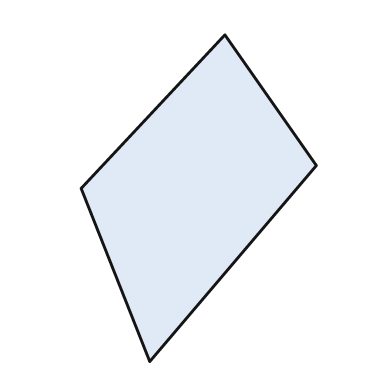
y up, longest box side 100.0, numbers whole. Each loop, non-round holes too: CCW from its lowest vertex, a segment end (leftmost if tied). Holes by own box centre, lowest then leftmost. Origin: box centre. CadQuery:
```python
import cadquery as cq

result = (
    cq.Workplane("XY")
    .moveTo(-15.0, -50.0)
    .lineTo(36.0, 10.0)
    .lineTo(8.0, 50.0)
    .lineTo(-36.0, 3.0)
    .close()
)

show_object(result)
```